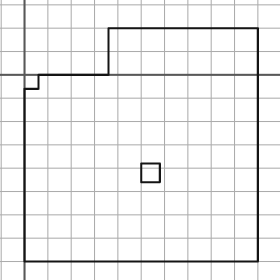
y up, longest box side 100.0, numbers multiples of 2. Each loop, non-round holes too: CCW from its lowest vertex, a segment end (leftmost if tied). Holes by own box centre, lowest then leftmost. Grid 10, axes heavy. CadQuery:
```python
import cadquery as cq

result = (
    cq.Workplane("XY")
    .moveTo(0.0, -80.0)
    .lineTo(100.0, -80.0)
    .lineTo(100.0, 20.0)
    .lineTo(36.0, 20.0)
    .lineTo(36.0, 0.0)
    .lineTo(6.0, 0.0)
    .lineTo(6.0, -6.0)
    .lineTo(0.0, -6.0)
    .close()
    .moveTo(50.0, -46.0)
    .lineTo(58.0, -46.0)
    .lineTo(58.0, -38.0)
    .lineTo(50.0, -38.0)
    .close()
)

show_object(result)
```